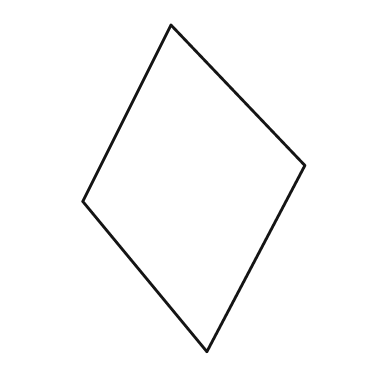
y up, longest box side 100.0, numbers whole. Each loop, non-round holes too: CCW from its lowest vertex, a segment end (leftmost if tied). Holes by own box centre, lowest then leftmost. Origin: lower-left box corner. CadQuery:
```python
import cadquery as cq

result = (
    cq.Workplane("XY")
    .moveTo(38.0, 0.0)
    .lineTo(68.0, 57.0)
    .lineTo(27.0, 100.0)
    .lineTo(0.0, 46.0)
    .close()
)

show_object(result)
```